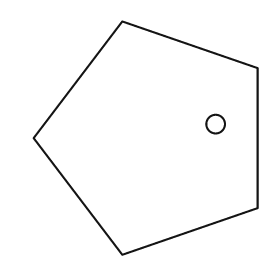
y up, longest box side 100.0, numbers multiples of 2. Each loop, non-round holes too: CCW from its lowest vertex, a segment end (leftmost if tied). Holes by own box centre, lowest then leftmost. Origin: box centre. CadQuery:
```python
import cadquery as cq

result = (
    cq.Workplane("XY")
    .moveTo(-10.0, -50.0)
    .lineTo(48.0, -30.0)
    .lineTo(48.0, 30.0)
    .lineTo(-10.0, 50.0)
    .lineTo(-48.0, 0.0)
    .close()
    .moveTo(30.0, 6.0)
    .circle(4.0)
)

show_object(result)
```